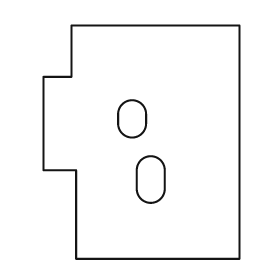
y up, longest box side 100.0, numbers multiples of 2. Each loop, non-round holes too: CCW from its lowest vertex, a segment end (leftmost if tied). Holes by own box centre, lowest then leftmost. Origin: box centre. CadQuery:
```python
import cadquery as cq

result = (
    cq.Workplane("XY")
    .moveTo(-28.0, -50.0)
    .lineTo(42.0, -50.0)
    .lineTo(42.0, 50.0)
    .lineTo(-30.0, 50.0)
    .lineTo(-30.0, 28.0)
    .lineTo(-42.0, 28.0)
    .lineTo(-42.0, -12.0)
    .lineTo(-28.0, -12.0)
    .close()
    .moveTo(-2.0, -20.0)
    .threePointArc((4.0, -26.0), (10.0, -20.0))
    .lineTo(10.0, -12.0)
    .threePointArc((4.0, -6.0), (-2.0, -12.0))
    .close()
    .moveTo(-10.0, 8.0)
    .threePointArc((-4.0, 2.0), (2.0, 8.0))
    .lineTo(2.0, 12.0)
    .threePointArc((-4.0, 18.0), (-10.0, 12.0))
    .close()
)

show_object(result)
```